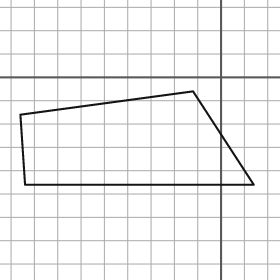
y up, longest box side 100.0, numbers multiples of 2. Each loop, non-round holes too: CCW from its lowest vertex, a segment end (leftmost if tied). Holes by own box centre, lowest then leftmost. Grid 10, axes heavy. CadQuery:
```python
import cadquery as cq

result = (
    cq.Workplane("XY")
    .moveTo(-84.0, -46.0)
    .lineTo(14.0, -46.0)
    .lineTo(-12.0, -6.0)
    .lineTo(-86.0, -16.0)
    .close()
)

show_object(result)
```